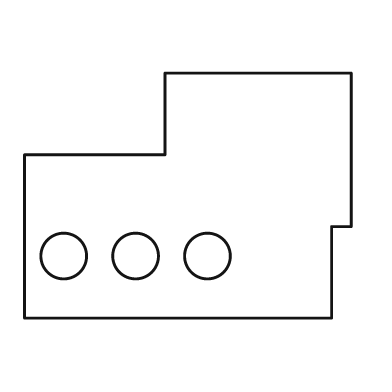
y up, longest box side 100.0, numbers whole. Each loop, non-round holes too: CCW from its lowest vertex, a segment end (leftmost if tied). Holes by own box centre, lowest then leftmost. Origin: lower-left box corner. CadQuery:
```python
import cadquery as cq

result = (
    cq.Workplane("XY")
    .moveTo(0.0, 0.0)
    .lineTo(94.0, 0.0)
    .lineTo(94.0, 28.0)
    .lineTo(100.0, 28.0)
    .lineTo(100.0, 75.0)
    .lineTo(43.0, 75.0)
    .lineTo(43.0, 50.0)
    .lineTo(0.0, 50.0)
    .close()
    .moveTo(12.0, 19.0)
    .circle(7.0)
    .moveTo(34.0, 19.0)
    .circle(7.0)
    .moveTo(56.0, 19.0)
    .circle(7.0)
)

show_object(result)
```